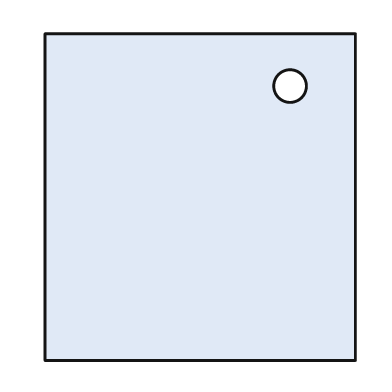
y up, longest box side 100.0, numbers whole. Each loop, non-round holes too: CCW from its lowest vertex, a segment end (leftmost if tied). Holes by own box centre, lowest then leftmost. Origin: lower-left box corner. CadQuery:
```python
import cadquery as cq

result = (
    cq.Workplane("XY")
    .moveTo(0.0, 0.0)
    .lineTo(95.0, 0.0)
    .lineTo(95.0, 100.0)
    .lineTo(0.0, 100.0)
    .close()
    .moveTo(75.0, 84.0)
    .circle(5.0)
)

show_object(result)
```